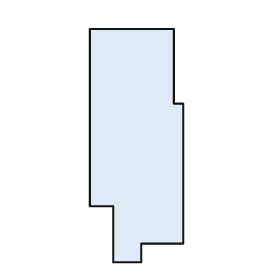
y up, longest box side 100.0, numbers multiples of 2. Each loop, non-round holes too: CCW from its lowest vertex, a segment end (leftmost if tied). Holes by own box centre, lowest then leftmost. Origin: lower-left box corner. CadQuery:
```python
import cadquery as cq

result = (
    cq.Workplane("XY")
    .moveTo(10.0, 0.0)
    .lineTo(22.0, 0.0)
    .lineTo(22.0, 8.0)
    .lineTo(40.0, 8.0)
    .lineTo(40.0, 68.0)
    .lineTo(36.0, 68.0)
    .lineTo(36.0, 100.0)
    .lineTo(0.0, 100.0)
    .lineTo(0.0, 24.0)
    .lineTo(10.0, 24.0)
    .close()
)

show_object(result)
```